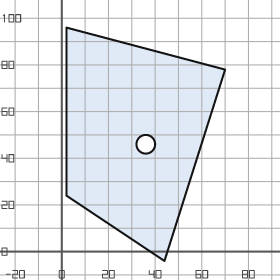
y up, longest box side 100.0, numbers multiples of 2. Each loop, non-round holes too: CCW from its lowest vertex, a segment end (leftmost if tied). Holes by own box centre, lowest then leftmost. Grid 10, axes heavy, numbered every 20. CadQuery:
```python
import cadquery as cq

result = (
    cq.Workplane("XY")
    .moveTo(44.0, -4.0)
    .lineTo(70.0, 78.0)
    .lineTo(2.0, 96.0)
    .lineTo(2.0, 24.0)
    .close()
    .moveTo(36.0, 46.0)
    .circle(4.0)
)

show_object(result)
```